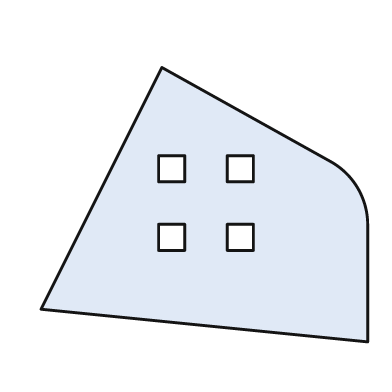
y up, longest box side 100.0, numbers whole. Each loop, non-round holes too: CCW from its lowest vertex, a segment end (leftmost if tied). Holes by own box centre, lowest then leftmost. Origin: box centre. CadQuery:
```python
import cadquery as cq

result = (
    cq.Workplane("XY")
    .moveTo(50.0, -42.0)
    .lineTo(50.0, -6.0)
    .threePointArc((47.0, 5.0), (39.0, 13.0))
    .lineTo(-13.0, 42.0)
    .lineTo(-50.0, -32.0)
    .close()
    .moveTo(-14.0, -14.0)
    .lineTo(-6.0, -14.0)
    .lineTo(-6.0, -6.0)
    .lineTo(-14.0, -6.0)
    .close()
    .moveTo(7.0, -14.0)
    .lineTo(15.0, -14.0)
    .lineTo(15.0, -6.0)
    .lineTo(7.0, -6.0)
    .close()
    .moveTo(-14.0, 7.0)
    .lineTo(-6.0, 7.0)
    .lineTo(-6.0, 15.0)
    .lineTo(-14.0, 15.0)
    .close()
    .moveTo(7.0, 7.0)
    .lineTo(15.0, 7.0)
    .lineTo(15.0, 15.0)
    .lineTo(7.0, 15.0)
    .close()
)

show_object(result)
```